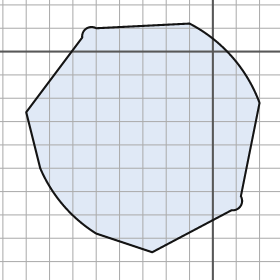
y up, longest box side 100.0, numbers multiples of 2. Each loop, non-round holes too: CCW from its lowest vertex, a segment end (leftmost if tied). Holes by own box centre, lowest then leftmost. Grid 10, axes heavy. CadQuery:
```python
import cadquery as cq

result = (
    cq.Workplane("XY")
    .moveTo(-26.0, -86.0)
    .lineTo(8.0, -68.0)
    .threePointArc((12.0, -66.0), (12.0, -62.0))
    .lineTo(20.0, -22.0)
    .threePointArc((8.0, -2.0), (-10.0, 12.0))
    .lineTo(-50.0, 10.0)
    .threePointArc((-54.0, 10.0), (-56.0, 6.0))
    .lineTo(-80.0, -26.0)
    .lineTo(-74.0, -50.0)
    .threePointArc((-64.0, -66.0), (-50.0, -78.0))
    .close()
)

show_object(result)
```